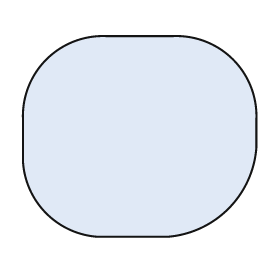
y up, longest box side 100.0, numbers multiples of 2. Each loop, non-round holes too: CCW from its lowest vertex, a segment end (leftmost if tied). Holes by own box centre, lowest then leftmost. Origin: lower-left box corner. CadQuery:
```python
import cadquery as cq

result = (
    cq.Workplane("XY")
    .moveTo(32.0, 0.0)
    .lineTo(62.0, 0.0)
    .threePointArc((88.0, 12.0), (100.0, 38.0))
    .lineTo(100.0, 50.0)
    .threePointArc((90.0, 76.0), (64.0, 86.0))
    .lineTo(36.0, 86.0)
    .threePointArc((10.0, 76.0), (0.0, 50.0))
    .lineTo(0.0, 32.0)
    .threePointArc((10.0, 10.0), (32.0, 0.0))
    .close()
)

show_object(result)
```